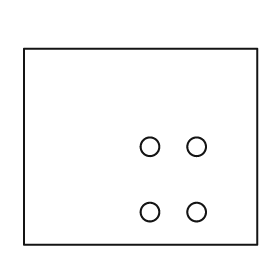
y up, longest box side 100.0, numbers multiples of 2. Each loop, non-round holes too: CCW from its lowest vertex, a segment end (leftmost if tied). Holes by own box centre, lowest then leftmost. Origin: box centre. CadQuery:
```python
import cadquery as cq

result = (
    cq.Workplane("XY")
    .moveTo(-50.0, -42.0)
    .lineTo(50.0, -42.0)
    .lineTo(50.0, 42.0)
    .lineTo(-50.0, 42.0)
    .close()
    .moveTo(4.0, -28.0)
    .circle(4.0)
    .moveTo(24.0, -28.0)
    .circle(4.0)
    .moveTo(4.0, 0.0)
    .circle(4.0)
    .moveTo(24.0, 0.0)
    .circle(4.0)
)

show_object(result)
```